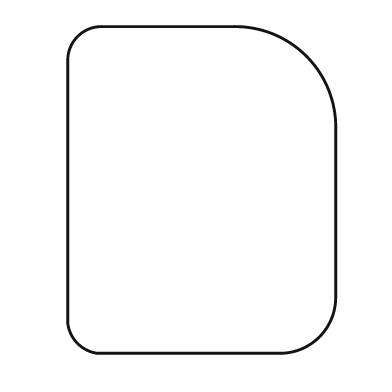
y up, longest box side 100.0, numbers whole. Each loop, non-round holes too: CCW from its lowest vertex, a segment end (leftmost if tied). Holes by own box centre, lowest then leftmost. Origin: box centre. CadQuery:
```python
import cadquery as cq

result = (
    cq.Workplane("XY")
    .moveTo(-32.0, -50.0)
    .lineTo(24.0, -50.0)
    .threePointArc((36.0, -45.0), (41.0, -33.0))
    .lineTo(41.0, 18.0)
    .threePointArc((32.0, 41.0), (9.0, 50.0))
    .lineTo(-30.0, 50.0)
    .threePointArc((-38.0, 47.0), (-41.0, 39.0))
    .lineTo(-41.0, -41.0)
    .threePointArc((-38.0, -47.0), (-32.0, -50.0))
    .close()
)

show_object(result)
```